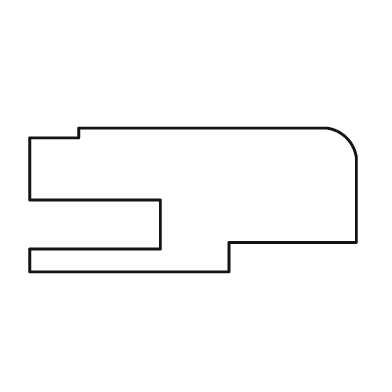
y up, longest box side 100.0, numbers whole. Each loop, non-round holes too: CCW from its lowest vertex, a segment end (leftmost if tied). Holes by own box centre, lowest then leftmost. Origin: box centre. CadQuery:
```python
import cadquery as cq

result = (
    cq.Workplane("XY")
    .moveTo(-50.0, -22.0)
    .lineTo(11.0, -22.0)
    .lineTo(11.0, -13.0)
    .lineTo(50.0, -13.0)
    .lineTo(50.0, 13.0)
    .threePointArc((47.0, 19.0), (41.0, 22.0))
    .lineTo(-35.0, 22.0)
    .lineTo(-35.0, 19.0)
    .lineTo(-50.0, 19.0)
    .lineTo(-50.0, 0.0)
    .lineTo(-10.0, 0.0)
    .lineTo(-10.0, -15.0)
    .lineTo(-50.0, -15.0)
    .close()
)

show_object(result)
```